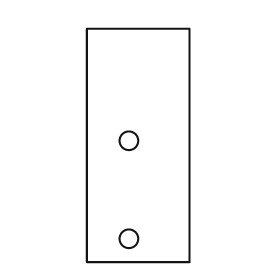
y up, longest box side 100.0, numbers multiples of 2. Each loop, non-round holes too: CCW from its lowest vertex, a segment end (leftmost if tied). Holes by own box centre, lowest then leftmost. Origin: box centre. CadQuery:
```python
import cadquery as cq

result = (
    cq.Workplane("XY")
    .moveTo(-22.0, -50.0)
    .lineTo(22.0, -50.0)
    .lineTo(22.0, 50.0)
    .lineTo(-22.0, 50.0)
    .close()
    .moveTo(-4.0, -40.0)
    .circle(4.0)
    .moveTo(-4.0, 2.0)
    .circle(4.0)
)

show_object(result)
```